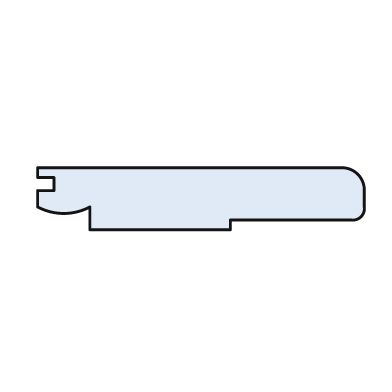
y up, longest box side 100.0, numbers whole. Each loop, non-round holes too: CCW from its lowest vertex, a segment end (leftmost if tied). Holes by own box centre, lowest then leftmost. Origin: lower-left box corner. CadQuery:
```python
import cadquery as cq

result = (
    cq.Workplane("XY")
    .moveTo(16.0, 0.0)
    .lineTo(59.0, 0.0)
    .lineTo(59.0, 3.0)
    .lineTo(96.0, 3.0)
    .threePointArc((99.0, 4.0), (100.0, 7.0))
    .lineTo(100.0, 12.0)
    .threePointArc((98.0, 17.0), (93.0, 19.0))
    .lineTo(0.0, 19.0)
    .lineTo(0.0, 16.0)
    .lineTo(5.0, 16.0)
    .lineTo(5.0, 12.0)
    .lineTo(0.0, 12.0)
    .lineTo(0.0, 7.0)
    .threePointArc((8.0, 5.0), (16.0, 7.0))
    .close()
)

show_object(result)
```